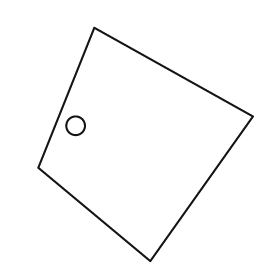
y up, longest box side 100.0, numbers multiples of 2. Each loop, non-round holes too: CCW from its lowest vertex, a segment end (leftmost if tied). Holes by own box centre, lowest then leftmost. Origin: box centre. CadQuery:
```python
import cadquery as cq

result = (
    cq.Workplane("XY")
    .moveTo(2.0, -50.0)
    .lineTo(46.0, 12.0)
    .lineTo(-22.0, 50.0)
    .lineTo(-46.0, -10.0)
    .close()
    .moveTo(-30.0, 8.0)
    .circle(4.0)
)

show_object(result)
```